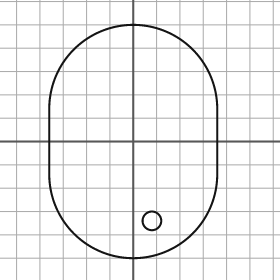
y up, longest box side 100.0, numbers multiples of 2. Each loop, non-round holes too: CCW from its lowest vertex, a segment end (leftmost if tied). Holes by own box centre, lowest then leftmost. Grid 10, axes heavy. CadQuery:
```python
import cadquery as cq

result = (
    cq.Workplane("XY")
    .moveTo(-36.0, -14.0)
    .threePointArc((0.0, -50.0), (36.0, -14.0))
    .lineTo(36.0, 14.0)
    .threePointArc((0.0, 50.0), (-36.0, 14.0))
    .close()
    .moveTo(8.0, -34.0)
    .circle(4.0)
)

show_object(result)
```